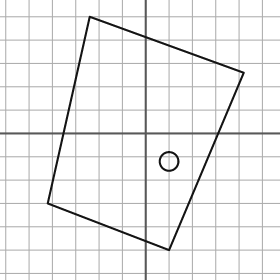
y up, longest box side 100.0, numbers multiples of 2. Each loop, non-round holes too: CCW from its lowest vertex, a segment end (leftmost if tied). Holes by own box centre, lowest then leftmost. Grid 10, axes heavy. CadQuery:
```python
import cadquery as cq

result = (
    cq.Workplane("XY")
    .moveTo(10.0, -50.0)
    .lineTo(42.0, 26.0)
    .lineTo(-24.0, 50.0)
    .lineTo(-42.0, -30.0)
    .close()
    .moveTo(10.0, -12.0)
    .circle(4.0)
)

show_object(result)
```